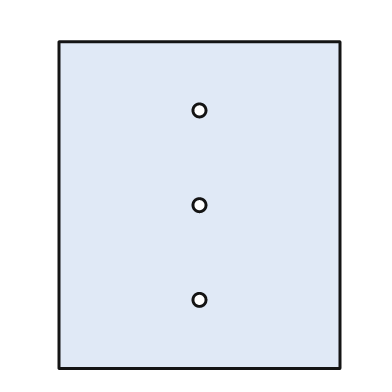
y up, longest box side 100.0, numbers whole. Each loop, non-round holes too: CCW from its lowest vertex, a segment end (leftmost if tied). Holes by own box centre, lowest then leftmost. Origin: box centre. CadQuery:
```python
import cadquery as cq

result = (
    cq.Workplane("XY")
    .moveTo(-43.0, -50.0)
    .lineTo(43.0, -50.0)
    .lineTo(43.0, 50.0)
    .lineTo(-43.0, 50.0)
    .close()
    .moveTo(0.0, -29.0)
    .circle(2.0)
    .moveTo(0.0, 0.0)
    .circle(2.0)
    .moveTo(0.0, 29.0)
    .circle(2.0)
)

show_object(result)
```